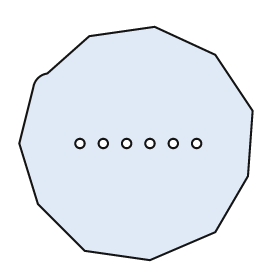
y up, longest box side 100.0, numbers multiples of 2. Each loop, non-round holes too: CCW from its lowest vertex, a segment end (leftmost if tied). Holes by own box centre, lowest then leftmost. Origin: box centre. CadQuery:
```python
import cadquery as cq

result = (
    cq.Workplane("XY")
    .moveTo(6.0, -50.0)
    .lineTo(34.0, -38.0)
    .lineTo(48.0, -14.0)
    .lineTo(50.0, 14.0)
    .lineTo(34.0, 38.0)
    .lineTo(8.0, 50.0)
    .lineTo(-20.0, 46.0)
    .lineTo(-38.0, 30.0)
    .threePointArc((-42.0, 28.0), (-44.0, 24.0))
    .lineTo(-50.0, 0.0)
    .lineTo(-42.0, -26.0)
    .lineTo(-22.0, -46.0)
    .close()
    .moveTo(-24.0, 0.0)
    .circle(2.0)
    .moveTo(-14.0, 0.0)
    .circle(2.0)
    .moveTo(-4.0, 0.0)
    .circle(2.0)
    .moveTo(6.0, 0.0)
    .circle(2.0)
    .moveTo(16.0, 0.0)
    .circle(2.0)
    .moveTo(26.0, 0.0)
    .circle(2.0)
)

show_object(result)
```